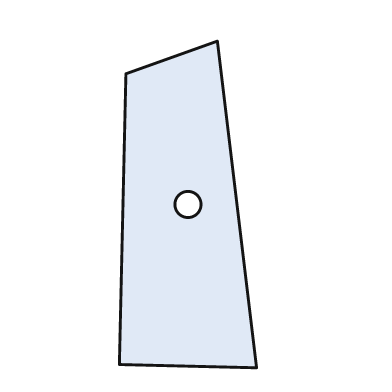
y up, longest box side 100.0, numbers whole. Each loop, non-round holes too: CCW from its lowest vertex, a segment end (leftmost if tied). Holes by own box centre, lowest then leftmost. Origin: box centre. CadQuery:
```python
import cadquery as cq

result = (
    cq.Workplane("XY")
    .moveTo(21.0, -50.0)
    .lineTo(9.0, 50.0)
    .lineTo(-19.0, 40.0)
    .lineTo(-21.0, -49.0)
    .close()
    .moveTo(0.0, 0.0)
    .circle(4.0)
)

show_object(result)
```